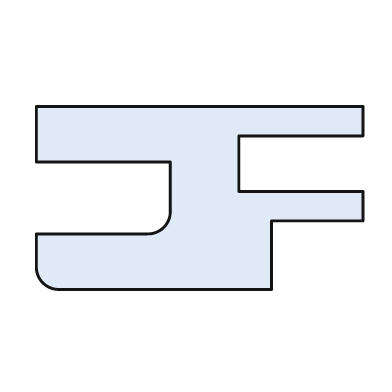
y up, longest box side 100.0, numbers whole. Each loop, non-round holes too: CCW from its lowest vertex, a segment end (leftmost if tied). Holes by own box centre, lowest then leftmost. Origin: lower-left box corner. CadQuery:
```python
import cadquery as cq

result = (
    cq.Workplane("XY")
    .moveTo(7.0, 0.0)
    .lineTo(72.0, 0.0)
    .lineTo(72.0, 21.0)
    .lineTo(100.0, 21.0)
    .lineTo(100.0, 30.0)
    .lineTo(62.0, 30.0)
    .lineTo(62.0, 47.0)
    .lineTo(100.0, 47.0)
    .lineTo(100.0, 56.0)
    .lineTo(0.0, 56.0)
    .lineTo(0.0, 39.0)
    .lineTo(41.0, 39.0)
    .lineTo(41.0, 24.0)
    .threePointArc((39.0, 19.0), (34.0, 17.0))
    .lineTo(0.0, 17.0)
    .lineTo(0.0, 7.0)
    .threePointArc((2.0, 2.0), (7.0, 0.0))
    .close()
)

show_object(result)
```